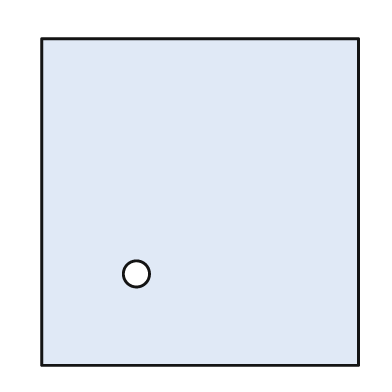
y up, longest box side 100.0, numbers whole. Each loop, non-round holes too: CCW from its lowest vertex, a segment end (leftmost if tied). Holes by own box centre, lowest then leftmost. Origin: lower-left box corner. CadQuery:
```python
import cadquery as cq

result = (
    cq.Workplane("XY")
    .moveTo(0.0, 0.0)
    .lineTo(97.0, 0.0)
    .lineTo(97.0, 100.0)
    .lineTo(0.0, 100.0)
    .close()
    .moveTo(29.0, 28.0)
    .circle(4.0)
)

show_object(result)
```